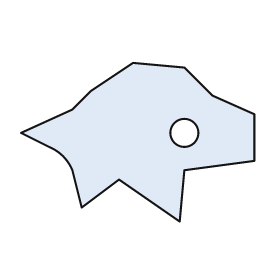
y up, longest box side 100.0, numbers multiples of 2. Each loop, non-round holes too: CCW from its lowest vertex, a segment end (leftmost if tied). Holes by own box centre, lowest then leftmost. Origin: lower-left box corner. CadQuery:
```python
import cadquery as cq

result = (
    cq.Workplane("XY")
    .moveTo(68.0, 0.0)
    .lineTo(70.0, 22.0)
    .lineTo(100.0, 26.0)
    .lineTo(100.0, 46.0)
    .lineTo(82.0, 54.0)
    .lineTo(70.0, 66.0)
    .lineTo(48.0, 68.0)
    .lineTo(30.0, 56.0)
    .lineTo(22.0, 48.0)
    .lineTo(0.0, 38.0)
    .lineTo(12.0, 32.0)
    .threePointArc((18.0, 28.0), (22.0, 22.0))
    .lineTo(26.0, 6.0)
    .lineTo(42.0, 18.0)
    .close()
    .moveTo(70.0, 38.0)
    .circle(6.0)
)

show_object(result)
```